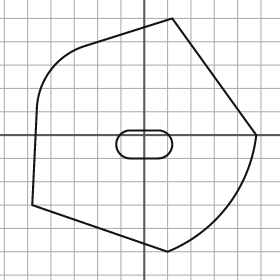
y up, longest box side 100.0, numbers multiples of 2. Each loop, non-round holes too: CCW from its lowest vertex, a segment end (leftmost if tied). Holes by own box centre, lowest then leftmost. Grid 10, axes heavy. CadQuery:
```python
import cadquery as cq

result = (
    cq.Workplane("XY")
    .moveTo(10.0, -50.0)
    .threePointArc((36.0, -30.0), (48.0, 0.0))
    .lineTo(12.0, 50.0)
    .lineTo(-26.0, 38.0)
    .threePointArc((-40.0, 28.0), (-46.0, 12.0))
    .lineTo(-48.0, -30.0)
    .close()
    .moveTo(-6.0, -10.0)
    .lineTo(6.0, -10.0)
    .threePointArc((12.0, -4.0), (6.0, 2.0))
    .lineTo(-6.0, 2.0)
    .threePointArc((-12.0, -4.0), (-6.0, -10.0))
    .close()
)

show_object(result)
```